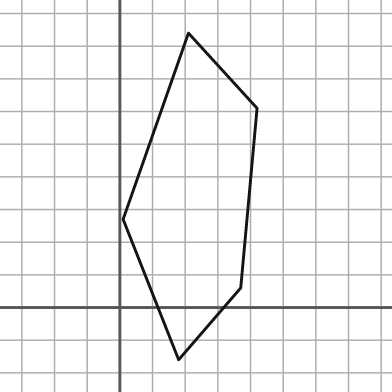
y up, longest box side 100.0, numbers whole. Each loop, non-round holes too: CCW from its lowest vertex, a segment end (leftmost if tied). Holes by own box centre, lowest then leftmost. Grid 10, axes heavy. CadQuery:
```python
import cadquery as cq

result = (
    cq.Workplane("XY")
    .moveTo(18.0, -16.0)
    .lineTo(37.0, 6.0)
    .lineTo(42.0, 61.0)
    .lineTo(21.0, 84.0)
    .lineTo(1.0, 27.0)
    .close()
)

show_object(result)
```